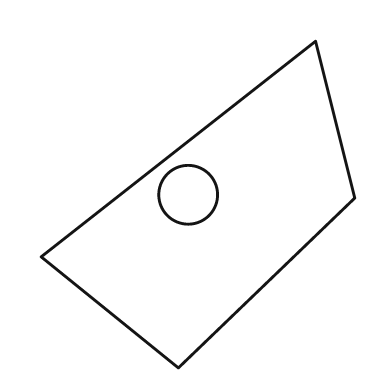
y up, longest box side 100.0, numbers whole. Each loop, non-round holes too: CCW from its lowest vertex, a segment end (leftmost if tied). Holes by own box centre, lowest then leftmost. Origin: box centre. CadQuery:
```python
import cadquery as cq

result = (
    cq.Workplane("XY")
    .moveTo(-6.0, -50.0)
    .lineTo(48.0, 2.0)
    .lineTo(36.0, 50.0)
    .lineTo(-48.0, -16.0)
    .close()
    .moveTo(-3.0, 3.0)
    .circle(9.0)
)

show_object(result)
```